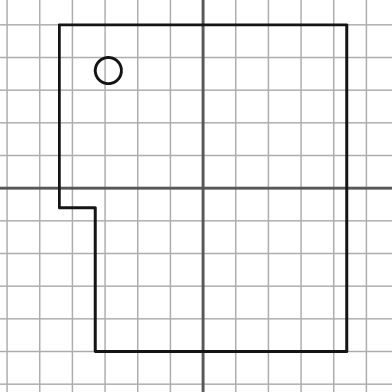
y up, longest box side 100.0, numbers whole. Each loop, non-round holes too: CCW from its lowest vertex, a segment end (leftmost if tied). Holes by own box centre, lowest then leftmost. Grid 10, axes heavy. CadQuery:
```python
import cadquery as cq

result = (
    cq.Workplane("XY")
    .moveTo(-33.0, -50.0)
    .lineTo(44.0, -50.0)
    .lineTo(44.0, 50.0)
    .lineTo(-44.0, 50.0)
    .lineTo(-44.0, -6.0)
    .lineTo(-33.0, -6.0)
    .close()
    .moveTo(-29.0, 36.0)
    .circle(4.0)
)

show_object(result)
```